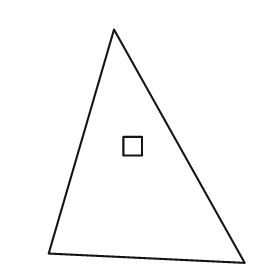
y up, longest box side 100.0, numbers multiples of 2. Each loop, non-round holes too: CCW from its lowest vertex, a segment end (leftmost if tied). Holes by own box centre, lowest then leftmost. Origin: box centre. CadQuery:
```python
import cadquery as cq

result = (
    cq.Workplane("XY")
    .moveTo(42.0, -50.0)
    .lineTo(-14.0, 50.0)
    .lineTo(-42.0, -46.0)
    .close()
    .moveTo(-10.0, -4.0)
    .lineTo(-2.0, -4.0)
    .lineTo(-2.0, 4.0)
    .lineTo(-10.0, 4.0)
    .close()
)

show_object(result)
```